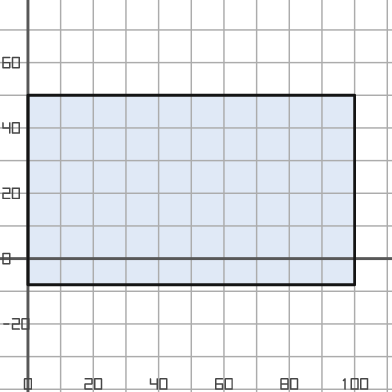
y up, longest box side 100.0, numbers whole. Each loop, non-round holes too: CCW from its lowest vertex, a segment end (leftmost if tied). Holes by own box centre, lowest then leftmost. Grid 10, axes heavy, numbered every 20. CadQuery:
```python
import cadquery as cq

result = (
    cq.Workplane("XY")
    .moveTo(0.0, -8.0)
    .lineTo(100.0, -8.0)
    .lineTo(100.0, 50.0)
    .lineTo(0.0, 50.0)
    .close()
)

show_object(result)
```